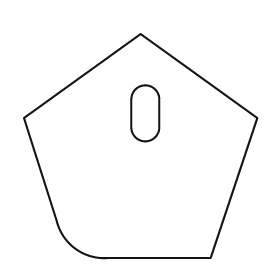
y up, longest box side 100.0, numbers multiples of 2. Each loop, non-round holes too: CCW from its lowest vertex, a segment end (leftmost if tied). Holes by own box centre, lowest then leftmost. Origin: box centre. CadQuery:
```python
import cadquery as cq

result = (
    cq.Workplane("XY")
    .moveTo(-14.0, -48.0)
    .lineTo(30.0, -48.0)
    .lineTo(50.0, 12.0)
    .lineTo(0.0, 48.0)
    .lineTo(-50.0, 12.0)
    .lineTo(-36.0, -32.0)
    .threePointArc((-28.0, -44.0), (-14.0, -48.0))
    .close()
    .moveTo(-4.0, 8.0)
    .threePointArc((2.0, 2.0), (8.0, 8.0))
    .lineTo(8.0, 20.0)
    .threePointArc((2.0, 26.0), (-4.0, 20.0))
    .close()
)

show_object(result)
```